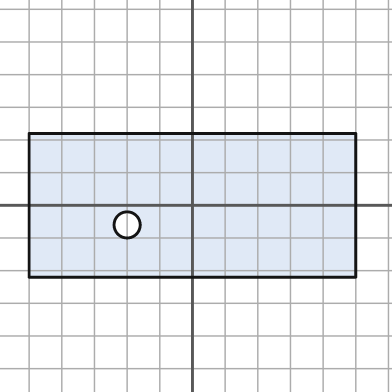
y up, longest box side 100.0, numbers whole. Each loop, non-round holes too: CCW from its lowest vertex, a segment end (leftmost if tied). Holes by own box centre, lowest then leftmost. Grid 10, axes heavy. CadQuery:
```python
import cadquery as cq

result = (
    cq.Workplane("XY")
    .moveTo(-50.0, -22.0)
    .lineTo(50.0, -22.0)
    .lineTo(50.0, 22.0)
    .lineTo(-50.0, 22.0)
    .close()
    .moveTo(-20.0, -6.0)
    .circle(4.0)
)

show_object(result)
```